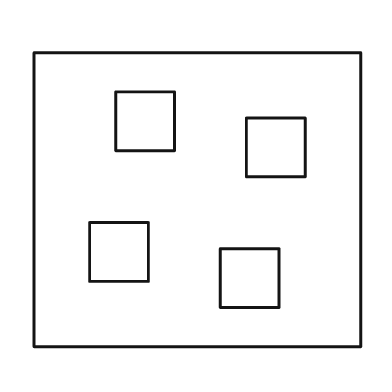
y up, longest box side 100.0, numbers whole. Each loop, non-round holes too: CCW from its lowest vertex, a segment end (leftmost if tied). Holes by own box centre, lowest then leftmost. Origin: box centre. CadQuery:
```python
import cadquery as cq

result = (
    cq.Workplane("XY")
    .moveTo(-50.0, -45.0)
    .lineTo(50.0, -45.0)
    .lineTo(50.0, 45.0)
    .lineTo(-50.0, 45.0)
    .close()
    .moveTo(7.0, -33.0)
    .lineTo(25.0, -33.0)
    .lineTo(25.0, -15.0)
    .lineTo(7.0, -15.0)
    .close()
    .moveTo(-33.0, -25.0)
    .lineTo(-15.0, -25.0)
    .lineTo(-15.0, -7.0)
    .lineTo(-33.0, -7.0)
    .close()
    .moveTo(15.0, 7.0)
    .lineTo(33.0, 7.0)
    .lineTo(33.0, 25.0)
    .lineTo(15.0, 25.0)
    .close()
    .moveTo(-25.0, 15.0)
    .lineTo(-7.0, 15.0)
    .lineTo(-7.0, 33.0)
    .lineTo(-25.0, 33.0)
    .close()
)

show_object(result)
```